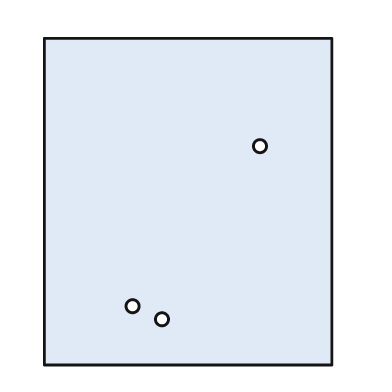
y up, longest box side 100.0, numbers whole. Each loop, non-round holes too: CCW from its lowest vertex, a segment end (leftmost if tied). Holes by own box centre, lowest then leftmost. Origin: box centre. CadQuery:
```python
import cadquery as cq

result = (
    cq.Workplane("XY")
    .moveTo(-44.0, -50.0)
    .lineTo(44.0, -50.0)
    .lineTo(44.0, 50.0)
    .lineTo(-44.0, 50.0)
    .close()
    .moveTo(-8.0, -36.0)
    .circle(2.0)
    .moveTo(-17.0, -32.0)
    .circle(2.0)
    .moveTo(22.0, 17.0)
    .circle(2.0)
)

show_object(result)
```